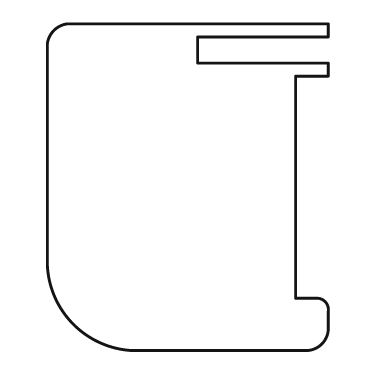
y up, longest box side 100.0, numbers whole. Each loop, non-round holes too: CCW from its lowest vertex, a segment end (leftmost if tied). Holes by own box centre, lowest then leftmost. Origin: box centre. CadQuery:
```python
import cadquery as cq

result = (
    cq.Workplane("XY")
    .moveTo(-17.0, -50.0)
    .lineTo(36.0, -50.0)
    .threePointArc((41.0, -48.0), (43.0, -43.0))
    .lineTo(43.0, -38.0)
    .threePointArc((42.0, -35.0), (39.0, -34.0))
    .lineTo(33.0, -34.0)
    .lineTo(33.0, 34.0)
    .lineTo(43.0, 34.0)
    .lineTo(43.0, 38.0)
    .lineTo(3.0, 38.0)
    .lineTo(3.0, 46.0)
    .lineTo(43.0, 46.0)
    .lineTo(43.0, 50.0)
    .lineTo(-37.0, 50.0)
    .threePointArc((-41.0, 48.0), (-43.0, 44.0))
    .lineTo(-43.0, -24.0)
    .threePointArc((-35.0, -42.0), (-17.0, -50.0))
    .close()
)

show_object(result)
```